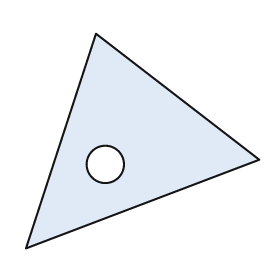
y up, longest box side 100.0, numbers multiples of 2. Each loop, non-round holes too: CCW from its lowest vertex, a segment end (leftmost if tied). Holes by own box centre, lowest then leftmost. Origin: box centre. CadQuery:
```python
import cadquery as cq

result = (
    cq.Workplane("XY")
    .moveTo(-50.0, -46.0)
    .lineTo(50.0, -8.0)
    .lineTo(-20.0, 46.0)
    .close()
    .moveTo(-16.0, -10.0)
    .circle(8.0)
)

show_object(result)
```